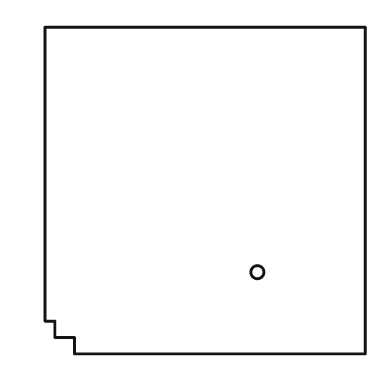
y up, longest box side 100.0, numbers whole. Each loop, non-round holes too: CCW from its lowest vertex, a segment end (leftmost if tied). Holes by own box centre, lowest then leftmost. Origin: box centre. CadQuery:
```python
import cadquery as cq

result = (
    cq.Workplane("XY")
    .moveTo(-40.0, -50.0)
    .lineTo(49.0, -50.0)
    .lineTo(49.0, 50.0)
    .lineTo(-49.0, 50.0)
    .lineTo(-49.0, -40.0)
    .lineTo(-46.0, -40.0)
    .lineTo(-46.0, -45.0)
    .lineTo(-40.0, -45.0)
    .close()
    .moveTo(16.0, -25.0)
    .circle(2.0)
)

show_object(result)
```